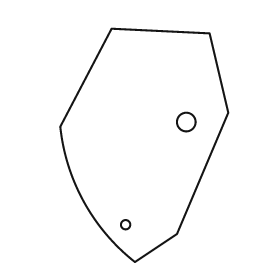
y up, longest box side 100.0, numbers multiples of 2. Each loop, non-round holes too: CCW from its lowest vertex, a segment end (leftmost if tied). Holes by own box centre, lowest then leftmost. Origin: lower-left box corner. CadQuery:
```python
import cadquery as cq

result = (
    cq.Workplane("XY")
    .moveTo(32.0, 0.0)
    .lineTo(50.0, 12.0)
    .lineTo(72.0, 64.0)
    .lineTo(64.0, 98.0)
    .lineTo(22.0, 100.0)
    .lineTo(0.0, 58.0)
    .threePointArc((10.0, 26.0), (32.0, 0.0))
    .close()
    .moveTo(28.0, 16.0)
    .circle(2.0)
    .moveTo(54.0, 60.0)
    .circle(4.0)
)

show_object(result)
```